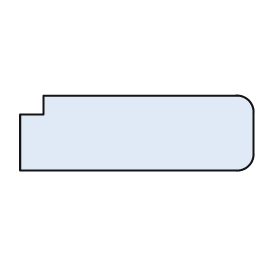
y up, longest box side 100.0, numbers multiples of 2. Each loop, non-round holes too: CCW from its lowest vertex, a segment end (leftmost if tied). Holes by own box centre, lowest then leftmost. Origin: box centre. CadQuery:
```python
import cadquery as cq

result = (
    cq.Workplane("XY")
    .moveTo(-50.0, -16.0)
    .lineTo(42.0, -16.0)
    .threePointArc((48.0, -14.0), (50.0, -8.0))
    .lineTo(50.0, 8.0)
    .threePointArc((48.0, 14.0), (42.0, 16.0))
    .lineTo(-40.0, 16.0)
    .lineTo(-40.0, 8.0)
    .lineTo(-50.0, 8.0)
    .close()
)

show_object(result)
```